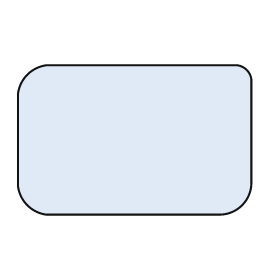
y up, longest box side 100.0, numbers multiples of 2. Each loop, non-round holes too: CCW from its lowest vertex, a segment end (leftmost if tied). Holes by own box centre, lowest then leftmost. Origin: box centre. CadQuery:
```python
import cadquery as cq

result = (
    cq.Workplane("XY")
    .moveTo(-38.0, -32.0)
    .lineTo(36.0, -32.0)
    .threePointArc((46.0, -28.0), (50.0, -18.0))
    .lineTo(50.0, 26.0)
    .threePointArc((48.0, 30.0), (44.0, 32.0))
    .lineTo(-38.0, 32.0)
    .threePointArc((-46.0, 28.0), (-50.0, 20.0))
    .lineTo(-50.0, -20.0)
    .threePointArc((-46.0, -28.0), (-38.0, -32.0))
    .close()
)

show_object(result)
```